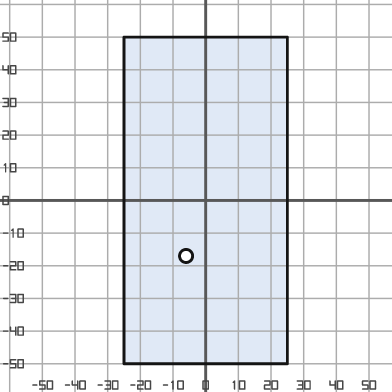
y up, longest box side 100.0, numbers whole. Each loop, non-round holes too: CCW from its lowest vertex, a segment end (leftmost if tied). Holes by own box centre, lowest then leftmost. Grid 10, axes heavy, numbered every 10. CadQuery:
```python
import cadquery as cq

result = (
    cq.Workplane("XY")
    .moveTo(-25.0, -50.0)
    .lineTo(25.0, -50.0)
    .lineTo(25.0, 50.0)
    .lineTo(-25.0, 50.0)
    .close()
    .moveTo(-6.0, -17.0)
    .circle(2.0)
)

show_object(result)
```